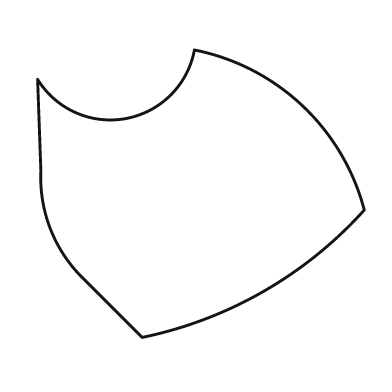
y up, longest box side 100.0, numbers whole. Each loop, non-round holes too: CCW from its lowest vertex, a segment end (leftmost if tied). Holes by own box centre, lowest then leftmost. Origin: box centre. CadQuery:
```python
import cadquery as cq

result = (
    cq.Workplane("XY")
    .moveTo(-18.0, -44.0)
    .threePointArc((19.0, -30.0), (50.0, -5.0))
    .threePointArc((31.0, 27.0), (-2.0, 44.0))
    .threePointArc((-23.0, 23.0), (-50.0, 35.0))
    .lineTo(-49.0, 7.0)
    .threePointArc((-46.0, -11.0), (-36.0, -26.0))
    .close()
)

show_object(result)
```